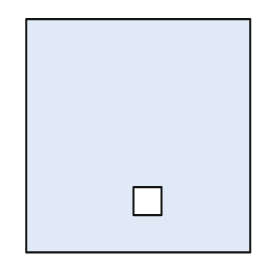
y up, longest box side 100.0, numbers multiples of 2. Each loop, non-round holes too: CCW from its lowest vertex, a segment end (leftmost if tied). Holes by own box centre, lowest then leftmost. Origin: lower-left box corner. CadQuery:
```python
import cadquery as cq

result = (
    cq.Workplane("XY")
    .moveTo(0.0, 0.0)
    .lineTo(96.0, 0.0)
    .lineTo(96.0, 100.0)
    .lineTo(0.0, 100.0)
    .close()
    .moveTo(46.0, 16.0)
    .lineTo(58.0, 16.0)
    .lineTo(58.0, 28.0)
    .lineTo(46.0, 28.0)
    .close()
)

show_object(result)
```